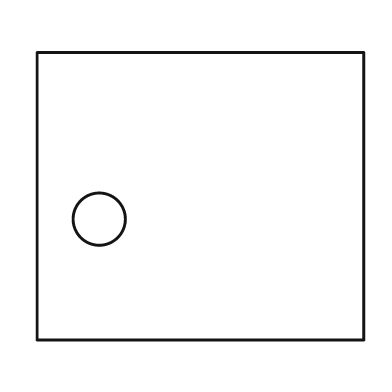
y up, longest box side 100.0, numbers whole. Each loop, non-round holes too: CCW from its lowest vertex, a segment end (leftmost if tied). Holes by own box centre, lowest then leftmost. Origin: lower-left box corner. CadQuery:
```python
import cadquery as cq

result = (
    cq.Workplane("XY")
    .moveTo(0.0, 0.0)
    .lineTo(100.0, 0.0)
    .lineTo(100.0, 88.0)
    .lineTo(0.0, 88.0)
    .close()
    .moveTo(19.0, 37.0)
    .circle(8.0)
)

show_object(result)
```